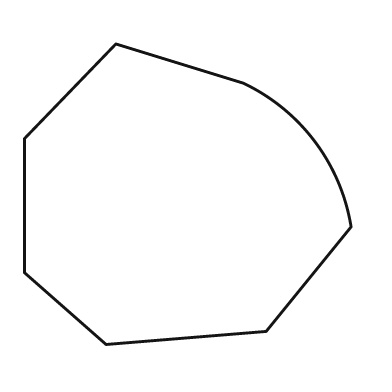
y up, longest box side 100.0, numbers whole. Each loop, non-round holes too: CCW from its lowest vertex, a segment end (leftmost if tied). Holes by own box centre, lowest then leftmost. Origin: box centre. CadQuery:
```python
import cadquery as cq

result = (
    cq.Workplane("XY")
    .moveTo(-25.0, -46.0)
    .lineTo(24.0, -42.0)
    .lineTo(50.0, -10.0)
    .threePointArc((39.0, 16.0), (17.0, 34.0))
    .lineTo(-22.0, 46.0)
    .lineTo(-50.0, 17.0)
    .lineTo(-50.0, -24.0)
    .close()
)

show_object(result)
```